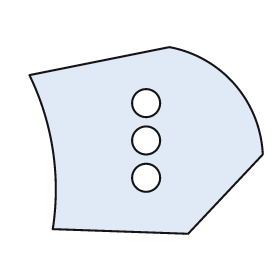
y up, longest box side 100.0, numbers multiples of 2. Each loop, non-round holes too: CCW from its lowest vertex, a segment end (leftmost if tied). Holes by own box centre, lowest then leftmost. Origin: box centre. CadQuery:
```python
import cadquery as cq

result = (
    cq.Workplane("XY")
    .moveTo(18.0, -40.0)
    .lineTo(50.0, -6.0)
    .threePointArc((38.0, 24.0), (10.0, 40.0))
    .lineTo(-50.0, 28.0)
    .threePointArc((-40.0, -4.0), (-40.0, -38.0))
    .close()
    .moveTo(0.0, -16.0)
    .circle(6.0)
    .moveTo(0.0, 0.0)
    .circle(6.0)
    .moveTo(0.0, 16.0)
    .circle(6.0)
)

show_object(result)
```